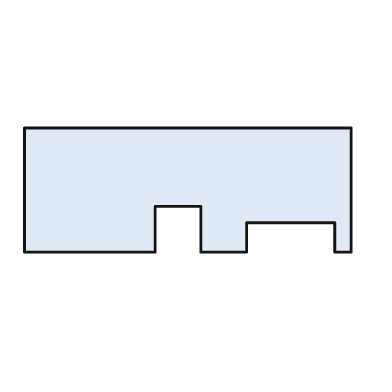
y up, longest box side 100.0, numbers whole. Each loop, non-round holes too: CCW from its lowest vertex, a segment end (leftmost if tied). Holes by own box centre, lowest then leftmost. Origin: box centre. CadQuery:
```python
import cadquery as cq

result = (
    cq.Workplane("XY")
    .moveTo(-50.0, -19.0)
    .lineTo(-10.0, -19.0)
    .lineTo(-10.0, -5.0)
    .lineTo(4.0, -5.0)
    .lineTo(4.0, -19.0)
    .lineTo(18.0, -19.0)
    .lineTo(18.0, -10.0)
    .lineTo(45.0, -10.0)
    .lineTo(45.0, -19.0)
    .lineTo(50.0, -19.0)
    .lineTo(50.0, 19.0)
    .lineTo(-50.0, 19.0)
    .close()
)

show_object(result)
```